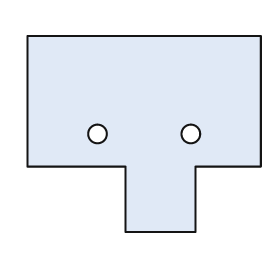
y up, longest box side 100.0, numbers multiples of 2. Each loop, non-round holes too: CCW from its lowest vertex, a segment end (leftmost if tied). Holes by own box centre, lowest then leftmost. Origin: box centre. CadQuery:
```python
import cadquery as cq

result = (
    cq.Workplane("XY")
    .moveTo(-8.0, -42.0)
    .lineTo(22.0, -42.0)
    .lineTo(22.0, -14.0)
    .lineTo(50.0, -14.0)
    .lineTo(50.0, 42.0)
    .lineTo(-50.0, 42.0)
    .lineTo(-50.0, -14.0)
    .lineTo(-8.0, -14.0)
    .close()
    .moveTo(-20.0, 0.0)
    .circle(4.0)
    .moveTo(20.0, 0.0)
    .circle(4.0)
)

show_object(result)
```